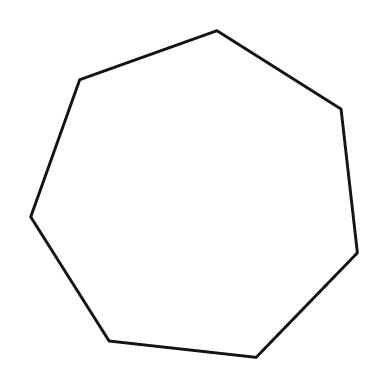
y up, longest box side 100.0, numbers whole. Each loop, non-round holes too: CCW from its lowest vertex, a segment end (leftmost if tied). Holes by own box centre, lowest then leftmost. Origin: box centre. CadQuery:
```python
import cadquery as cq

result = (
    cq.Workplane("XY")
    .moveTo(19.0, -50.0)
    .lineTo(50.0, -18.0)
    .lineTo(45.0, 26.0)
    .lineTo(7.0, 50.0)
    .lineTo(-35.0, 35.0)
    .lineTo(-50.0, -7.0)
    .lineTo(-26.0, -45.0)
    .close()
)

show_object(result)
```